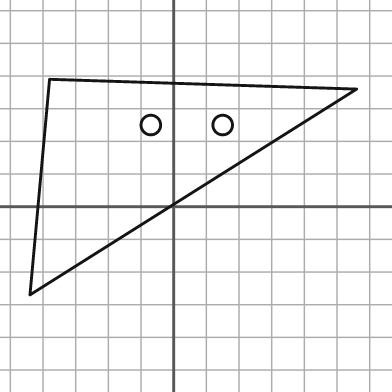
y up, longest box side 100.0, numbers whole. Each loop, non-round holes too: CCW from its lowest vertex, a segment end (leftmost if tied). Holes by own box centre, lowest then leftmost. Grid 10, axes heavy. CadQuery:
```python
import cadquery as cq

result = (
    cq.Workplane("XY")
    .moveTo(-44.0, -27.0)
    .lineTo(56.0, 36.0)
    .lineTo(-38.0, 39.0)
    .close()
    .moveTo(-7.0, 25.0)
    .circle(3.0)
    .moveTo(15.0, 25.0)
    .circle(3.0)
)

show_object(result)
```